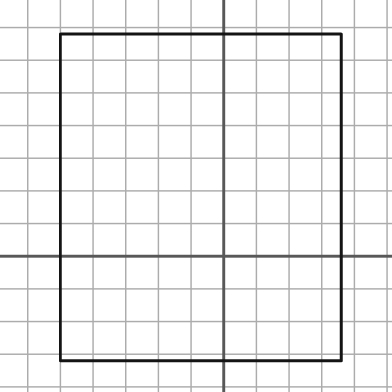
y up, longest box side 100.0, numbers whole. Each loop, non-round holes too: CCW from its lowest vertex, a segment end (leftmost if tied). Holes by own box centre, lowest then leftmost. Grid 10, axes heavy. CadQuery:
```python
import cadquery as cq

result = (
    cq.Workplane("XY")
    .moveTo(-50.0, -32.0)
    .lineTo(36.0, -32.0)
    .lineTo(36.0, 68.0)
    .lineTo(-50.0, 68.0)
    .close()
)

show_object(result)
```